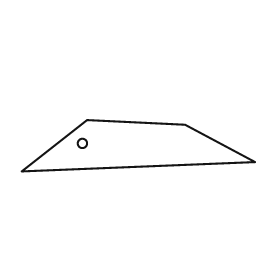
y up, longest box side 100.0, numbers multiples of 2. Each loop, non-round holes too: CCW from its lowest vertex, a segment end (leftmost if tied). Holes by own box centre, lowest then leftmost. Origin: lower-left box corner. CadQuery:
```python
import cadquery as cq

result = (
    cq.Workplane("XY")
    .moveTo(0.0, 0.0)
    .lineTo(100.0, 4.0)
    .lineTo(70.0, 20.0)
    .lineTo(28.0, 22.0)
    .close()
    .moveTo(26.0, 12.0)
    .circle(2.0)
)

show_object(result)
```